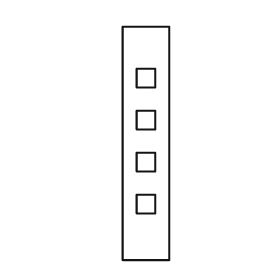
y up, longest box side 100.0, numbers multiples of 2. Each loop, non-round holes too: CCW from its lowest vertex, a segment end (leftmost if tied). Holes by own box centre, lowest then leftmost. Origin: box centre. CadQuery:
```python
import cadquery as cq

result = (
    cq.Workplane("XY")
    .moveTo(-10.0, -50.0)
    .lineTo(10.0, -50.0)
    .lineTo(10.0, 50.0)
    .lineTo(-10.0, 50.0)
    .close()
    .moveTo(-4.0, -30.0)
    .lineTo(4.0, -30.0)
    .lineTo(4.0, -22.0)
    .lineTo(-4.0, -22.0)
    .close()
    .moveTo(-4.0, -12.0)
    .lineTo(4.0, -12.0)
    .lineTo(4.0, -4.0)
    .lineTo(-4.0, -4.0)
    .close()
    .moveTo(-4.0, 6.0)
    .lineTo(4.0, 6.0)
    .lineTo(4.0, 14.0)
    .lineTo(-4.0, 14.0)
    .close()
    .moveTo(-4.0, 24.0)
    .lineTo(4.0, 24.0)
    .lineTo(4.0, 32.0)
    .lineTo(-4.0, 32.0)
    .close()
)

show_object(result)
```